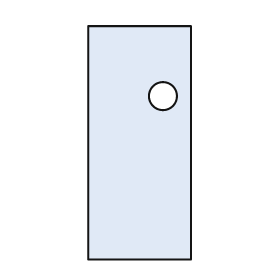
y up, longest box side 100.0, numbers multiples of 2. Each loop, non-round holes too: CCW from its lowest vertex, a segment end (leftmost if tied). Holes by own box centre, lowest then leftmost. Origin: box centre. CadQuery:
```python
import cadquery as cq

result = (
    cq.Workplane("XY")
    .moveTo(-22.0, -50.0)
    .lineTo(22.0, -50.0)
    .lineTo(22.0, 50.0)
    .lineTo(-22.0, 50.0)
    .close()
    .moveTo(10.0, 20.0)
    .circle(6.0)
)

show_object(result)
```